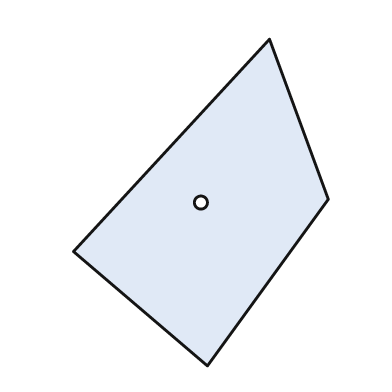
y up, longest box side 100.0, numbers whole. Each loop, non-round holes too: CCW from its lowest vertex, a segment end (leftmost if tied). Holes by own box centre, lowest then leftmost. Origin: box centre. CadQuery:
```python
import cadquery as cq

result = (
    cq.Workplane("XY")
    .moveTo(2.0, -50.0)
    .lineTo(39.0, 1.0)
    .lineTo(21.0, 50.0)
    .lineTo(-39.0, -15.0)
    .close()
    .moveTo(0.0, 0.0)
    .circle(2.0)
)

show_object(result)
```